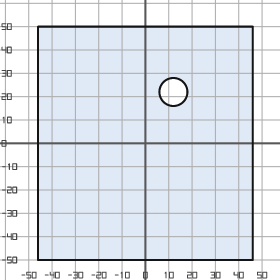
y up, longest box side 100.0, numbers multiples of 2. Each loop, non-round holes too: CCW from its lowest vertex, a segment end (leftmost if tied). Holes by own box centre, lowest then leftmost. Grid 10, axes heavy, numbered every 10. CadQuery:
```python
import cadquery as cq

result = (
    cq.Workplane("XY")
    .moveTo(-46.0, -50.0)
    .lineTo(46.0, -50.0)
    .lineTo(46.0, 50.0)
    .lineTo(-46.0, 50.0)
    .close()
    .moveTo(12.0, 22.0)
    .circle(6.0)
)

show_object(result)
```